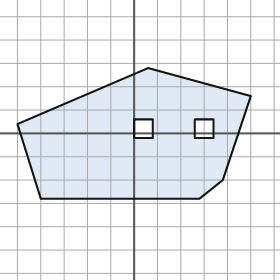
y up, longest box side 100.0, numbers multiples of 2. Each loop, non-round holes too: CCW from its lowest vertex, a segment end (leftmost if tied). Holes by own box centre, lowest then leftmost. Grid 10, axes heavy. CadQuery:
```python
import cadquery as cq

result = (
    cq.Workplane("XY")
    .moveTo(-40.0, -28.0)
    .lineTo(28.0, -28.0)
    .lineTo(38.0, -20.0)
    .lineTo(50.0, 16.0)
    .lineTo(6.0, 28.0)
    .lineTo(-50.0, 4.0)
    .close()
    .moveTo(0.0, -2.0)
    .lineTo(8.0, -2.0)
    .lineTo(8.0, 6.0)
    .lineTo(0.0, 6.0)
    .close()
    .moveTo(26.0, -2.0)
    .lineTo(34.0, -2.0)
    .lineTo(34.0, 6.0)
    .lineTo(26.0, 6.0)
    .close()
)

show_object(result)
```